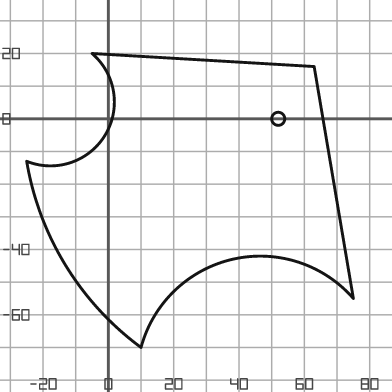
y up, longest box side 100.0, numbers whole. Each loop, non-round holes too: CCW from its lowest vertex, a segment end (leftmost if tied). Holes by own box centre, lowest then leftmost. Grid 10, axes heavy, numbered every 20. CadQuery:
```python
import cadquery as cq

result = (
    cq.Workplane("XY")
    .moveTo(10.0, -70.0)
    .threePointArc((38.0, -43.0), (75.0, -55.0))
    .lineTo(63.0, 16.0)
    .lineTo(-5.0, 20.0)
    .threePointArc((-1.0, -5.0), (-25.0, -13.0))
    .threePointArc((-13.0, -45.0), (10.0, -70.0))
    .close()
    .moveTo(52.0, 0.0)
    .circle(2.0)
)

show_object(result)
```